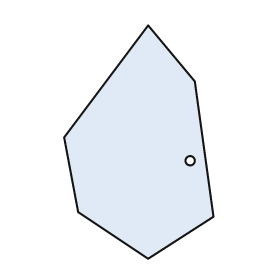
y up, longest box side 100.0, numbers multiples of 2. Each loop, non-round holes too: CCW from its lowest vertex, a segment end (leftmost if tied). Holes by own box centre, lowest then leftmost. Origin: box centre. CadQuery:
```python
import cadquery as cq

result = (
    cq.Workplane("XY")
    .moveTo(4.0, -50.0)
    .lineTo(32.0, -32.0)
    .lineTo(24.0, 26.0)
    .lineTo(4.0, 50.0)
    .lineTo(-32.0, 2.0)
    .lineTo(-26.0, -30.0)
    .close()
    .moveTo(22.0, -8.0)
    .circle(2.0)
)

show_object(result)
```